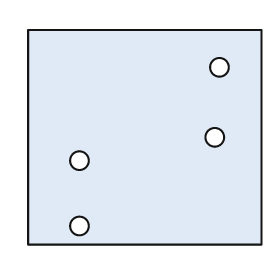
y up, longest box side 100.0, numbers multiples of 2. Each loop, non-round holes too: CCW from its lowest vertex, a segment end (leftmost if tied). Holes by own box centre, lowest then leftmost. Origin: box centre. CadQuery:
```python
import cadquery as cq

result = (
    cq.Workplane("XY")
    .moveTo(-50.0, -46.0)
    .lineTo(50.0, -46.0)
    .lineTo(50.0, 46.0)
    .lineTo(-50.0, 46.0)
    .close()
    .moveTo(-28.0, -38.0)
    .circle(4.0)
    .moveTo(-28.0, -10.0)
    .circle(4.0)
    .moveTo(30.0, 0.0)
    .circle(4.0)
    .moveTo(32.0, 30.0)
    .circle(4.0)
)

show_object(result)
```